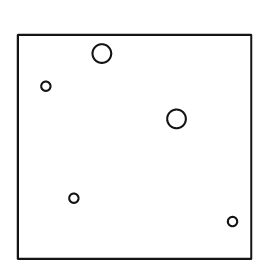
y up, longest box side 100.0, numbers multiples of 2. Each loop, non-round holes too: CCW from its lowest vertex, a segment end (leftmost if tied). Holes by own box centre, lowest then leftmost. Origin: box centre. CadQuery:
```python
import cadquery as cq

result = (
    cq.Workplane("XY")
    .moveTo(-50.0, -48.0)
    .lineTo(50.0, -48.0)
    .lineTo(50.0, 48.0)
    .lineTo(-50.0, 48.0)
    .close()
    .moveTo(42.0, -32.0)
    .circle(2.0)
    .moveTo(-26.0, -22.0)
    .circle(2.0)
    .moveTo(18.0, 12.0)
    .circle(4.0)
    .moveTo(-38.0, 26.0)
    .circle(2.0)
    .moveTo(-14.0, 40.0)
    .circle(4.0)
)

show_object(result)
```